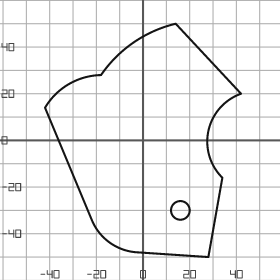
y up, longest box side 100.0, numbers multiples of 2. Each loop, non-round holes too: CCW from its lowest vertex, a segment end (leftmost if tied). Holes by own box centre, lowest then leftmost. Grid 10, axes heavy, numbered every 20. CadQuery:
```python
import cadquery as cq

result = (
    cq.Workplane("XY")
    .moveTo(28.0, -50.0)
    .lineTo(34.0, -16.0)
    .threePointArc((28.0, 4.0), (42.0, 20.0))
    .lineTo(14.0, 50.0)
    .threePointArc((-4.0, 42.0), (-18.0, 28.0))
    .threePointArc((-32.0, 24.0), (-42.0, 14.0))
    .lineTo(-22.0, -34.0)
    .threePointArc((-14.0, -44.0), (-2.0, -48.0))
    .close()
    .moveTo(16.0, -30.0)
    .circle(4.0)
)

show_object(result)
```